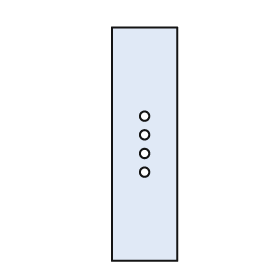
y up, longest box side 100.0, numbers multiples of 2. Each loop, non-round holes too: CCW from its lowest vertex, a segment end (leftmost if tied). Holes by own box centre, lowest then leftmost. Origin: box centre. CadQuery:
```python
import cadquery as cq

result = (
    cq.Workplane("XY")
    .moveTo(-14.0, -50.0)
    .lineTo(14.0, -50.0)
    .lineTo(14.0, 50.0)
    .lineTo(-14.0, 50.0)
    .close()
    .moveTo(0.0, -12.0)
    .circle(2.0)
    .moveTo(0.0, -4.0)
    .circle(2.0)
    .moveTo(0.0, 4.0)
    .circle(2.0)
    .moveTo(0.0, 12.0)
    .circle(2.0)
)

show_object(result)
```